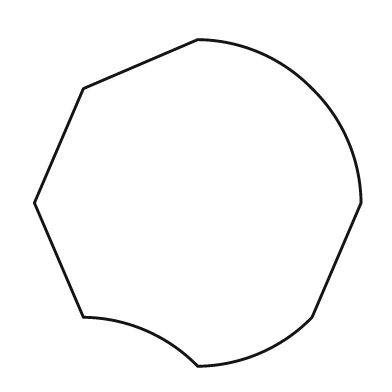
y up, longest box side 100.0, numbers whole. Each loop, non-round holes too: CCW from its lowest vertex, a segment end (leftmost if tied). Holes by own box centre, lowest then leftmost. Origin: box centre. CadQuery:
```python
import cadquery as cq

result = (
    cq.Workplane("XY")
    .moveTo(0.0, -50.0)
    .threePointArc((19.0, -46.0), (35.0, -35.0))
    .lineTo(50.0, 0.0)
    .threePointArc((46.0, 19.0), (35.0, 35.0))
    .threePointArc((19.0, 46.0), (0.0, 50.0))
    .lineTo(-35.0, 35.0)
    .lineTo(-50.0, 0.0)
    .lineTo(-35.0, -35.0)
    .threePointArc((-16.0, -39.0), (0.0, -50.0))
    .close()
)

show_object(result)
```